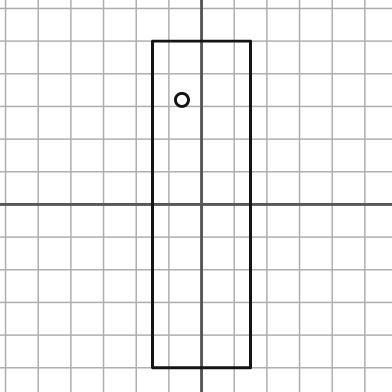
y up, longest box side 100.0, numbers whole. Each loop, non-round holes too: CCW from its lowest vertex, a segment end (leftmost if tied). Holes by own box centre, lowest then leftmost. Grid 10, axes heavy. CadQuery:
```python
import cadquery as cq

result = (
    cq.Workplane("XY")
    .moveTo(-15.0, -50.0)
    .lineTo(15.0, -50.0)
    .lineTo(15.0, 50.0)
    .lineTo(-15.0, 50.0)
    .close()
    .moveTo(-6.0, 32.0)
    .circle(2.0)
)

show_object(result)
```